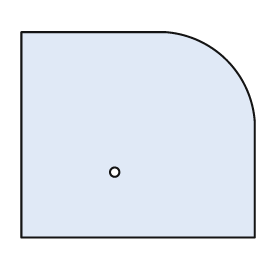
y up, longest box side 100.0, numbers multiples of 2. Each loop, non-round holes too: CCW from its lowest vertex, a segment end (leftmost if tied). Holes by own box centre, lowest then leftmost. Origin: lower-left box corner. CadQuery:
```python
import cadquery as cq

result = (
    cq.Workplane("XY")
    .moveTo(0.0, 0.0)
    .lineTo(100.0, 0.0)
    .lineTo(100.0, 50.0)
    .threePointArc((88.0, 76.0), (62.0, 88.0))
    .lineTo(0.0, 88.0)
    .close()
    .moveTo(40.0, 28.0)
    .circle(2.0)
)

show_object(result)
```